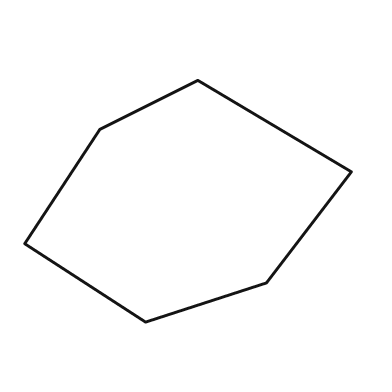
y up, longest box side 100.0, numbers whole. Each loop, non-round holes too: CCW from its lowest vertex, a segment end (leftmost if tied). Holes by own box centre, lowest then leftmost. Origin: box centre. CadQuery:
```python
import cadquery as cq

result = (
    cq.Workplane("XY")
    .moveTo(-13.0, -37.0)
    .lineTo(24.0, -25.0)
    .lineTo(50.0, 9.0)
    .lineTo(3.0, 37.0)
    .lineTo(-27.0, 22.0)
    .lineTo(-50.0, -13.0)
    .close()
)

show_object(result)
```